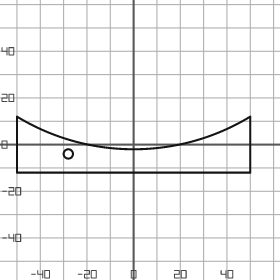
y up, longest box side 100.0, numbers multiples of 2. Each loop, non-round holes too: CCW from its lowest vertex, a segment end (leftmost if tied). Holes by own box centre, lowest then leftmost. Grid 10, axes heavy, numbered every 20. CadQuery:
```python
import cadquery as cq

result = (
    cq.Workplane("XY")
    .moveTo(-50.0, -12.0)
    .lineTo(50.0, -12.0)
    .lineTo(50.0, 12.0)
    .threePointArc((0.0, -2.0), (-50.0, 12.0))
    .close()
    .moveTo(-28.0, -4.0)
    .circle(2.0)
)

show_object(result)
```